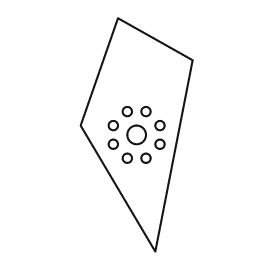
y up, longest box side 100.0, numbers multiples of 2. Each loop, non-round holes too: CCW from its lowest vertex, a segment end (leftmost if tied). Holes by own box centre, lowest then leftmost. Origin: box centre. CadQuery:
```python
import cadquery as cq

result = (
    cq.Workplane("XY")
    .moveTo(8.0, -50.0)
    .lineTo(24.0, 32.0)
    .lineTo(-8.0, 50.0)
    .lineTo(-24.0, 4.0)
    .close()
    .moveTo(-4.0, -10.0)
    .circle(2.0)
    .moveTo(4.0, -10.0)
    .circle(2.0)
    .moveTo(-10.0, -4.0)
    .circle(2.0)
    .moveTo(10.0, -4.0)
    .circle(2.0)
    .moveTo(0.0, 0.0)
    .circle(4.0)
    .moveTo(-10.0, 4.0)
    .circle(2.0)
    .moveTo(10.0, 4.0)
    .circle(2.0)
    .moveTo(-4.0, 10.0)
    .circle(2.0)
    .moveTo(4.0, 10.0)
    .circle(2.0)
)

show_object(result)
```